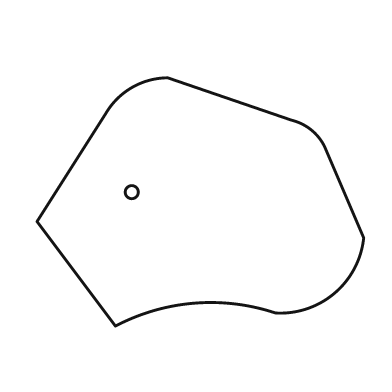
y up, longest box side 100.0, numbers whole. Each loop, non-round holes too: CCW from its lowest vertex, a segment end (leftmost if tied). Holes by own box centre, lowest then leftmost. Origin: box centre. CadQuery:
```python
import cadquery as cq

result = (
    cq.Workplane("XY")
    .moveTo(-26.0, -38.0)
    .threePointArc((-2.0, -31.0), (23.0, -34.0))
    .threePointArc((41.0, -28.0), (50.0, -11.0))
    .lineTo(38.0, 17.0)
    .threePointArc((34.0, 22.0), (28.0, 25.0))
    .lineTo(-10.0, 38.0)
    .threePointArc((-21.0, 35.0), (-29.0, 27.0))
    .lineTo(-50.0, -6.0)
    .close()
    .moveTo(-21.0, 3.0)
    .circle(2.0)
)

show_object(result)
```